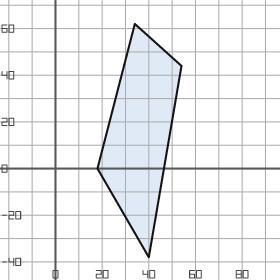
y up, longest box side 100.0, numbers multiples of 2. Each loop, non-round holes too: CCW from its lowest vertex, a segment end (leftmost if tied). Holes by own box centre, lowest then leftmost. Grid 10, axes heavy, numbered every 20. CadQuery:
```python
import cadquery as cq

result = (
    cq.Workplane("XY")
    .moveTo(40.0, -38.0)
    .lineTo(54.0, 44.0)
    .lineTo(34.0, 62.0)
    .lineTo(18.0, 0.0)
    .close()
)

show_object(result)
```